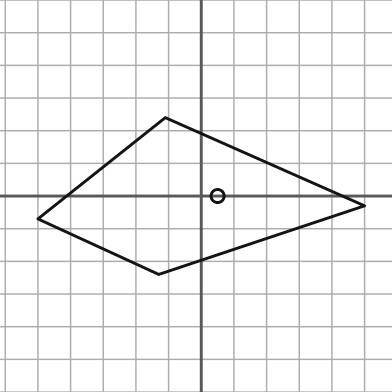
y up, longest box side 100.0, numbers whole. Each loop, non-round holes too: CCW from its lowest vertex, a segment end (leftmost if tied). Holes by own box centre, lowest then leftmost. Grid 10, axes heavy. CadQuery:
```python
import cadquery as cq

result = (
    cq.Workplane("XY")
    .moveTo(-13.0, -24.0)
    .lineTo(50.0, -3.0)
    .lineTo(-11.0, 24.0)
    .lineTo(-50.0, -7.0)
    .close()
    .moveTo(5.0, 0.0)
    .circle(2.0)
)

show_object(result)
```